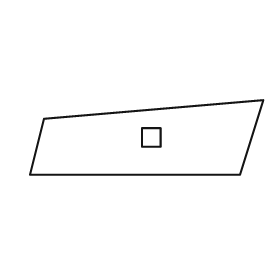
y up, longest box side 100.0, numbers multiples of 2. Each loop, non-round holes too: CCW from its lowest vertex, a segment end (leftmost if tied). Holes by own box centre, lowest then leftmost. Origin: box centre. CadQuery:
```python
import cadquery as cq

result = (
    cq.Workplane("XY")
    .moveTo(-50.0, -16.0)
    .lineTo(40.0, -16.0)
    .lineTo(50.0, 16.0)
    .lineTo(-44.0, 8.0)
    .close()
    .moveTo(-2.0, -4.0)
    .lineTo(6.0, -4.0)
    .lineTo(6.0, 4.0)
    .lineTo(-2.0, 4.0)
    .close()
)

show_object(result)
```